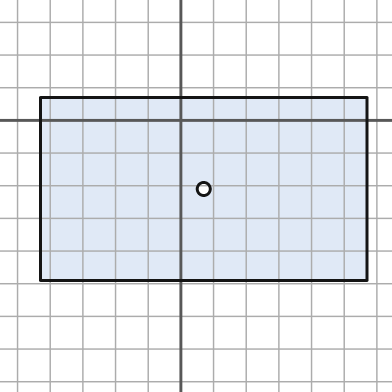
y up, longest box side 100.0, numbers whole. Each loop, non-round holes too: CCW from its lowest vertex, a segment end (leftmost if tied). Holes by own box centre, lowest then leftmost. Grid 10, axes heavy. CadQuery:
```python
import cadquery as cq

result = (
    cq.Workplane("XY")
    .moveTo(-43.0, -49.0)
    .lineTo(57.0, -49.0)
    .lineTo(57.0, 7.0)
    .lineTo(-43.0, 7.0)
    .close()
    .moveTo(7.0, -21.0)
    .circle(2.0)
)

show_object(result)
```